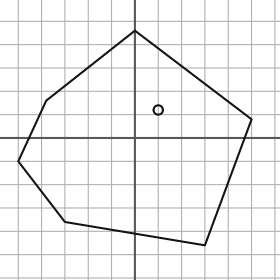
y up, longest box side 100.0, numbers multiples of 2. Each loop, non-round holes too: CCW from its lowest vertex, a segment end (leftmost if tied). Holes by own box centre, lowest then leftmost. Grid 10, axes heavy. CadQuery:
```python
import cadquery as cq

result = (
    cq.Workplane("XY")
    .moveTo(30.0, -46.0)
    .lineTo(50.0, 8.0)
    .lineTo(0.0, 46.0)
    .lineTo(-38.0, 16.0)
    .lineTo(-50.0, -10.0)
    .lineTo(-30.0, -36.0)
    .close()
    .moveTo(10.0, 12.0)
    .circle(2.0)
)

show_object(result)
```